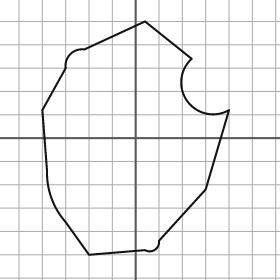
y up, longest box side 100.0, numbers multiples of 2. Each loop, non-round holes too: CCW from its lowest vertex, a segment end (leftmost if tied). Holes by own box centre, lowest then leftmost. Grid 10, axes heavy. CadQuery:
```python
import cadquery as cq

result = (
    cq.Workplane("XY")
    .moveTo(-20.0, -50.0)
    .lineTo(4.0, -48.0)
    .threePointArc((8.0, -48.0), (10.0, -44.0))
    .lineTo(30.0, -22.0)
    .lineTo(40.0, 12.0)
    .threePointArc((22.0, 16.0), (24.0, 34.0))
    .lineTo(4.0, 50.0)
    .lineTo(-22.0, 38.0)
    .threePointArc((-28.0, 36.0), (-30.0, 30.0))
    .lineTo(-40.0, 12.0)
    .lineTo(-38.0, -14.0)
    .threePointArc((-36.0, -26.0), (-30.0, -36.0))
    .close()
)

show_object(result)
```